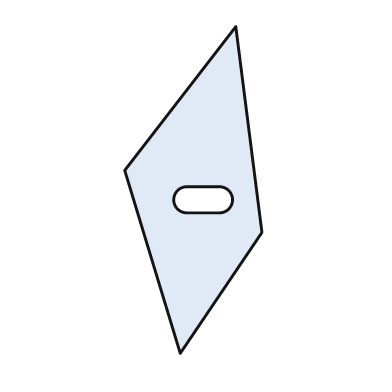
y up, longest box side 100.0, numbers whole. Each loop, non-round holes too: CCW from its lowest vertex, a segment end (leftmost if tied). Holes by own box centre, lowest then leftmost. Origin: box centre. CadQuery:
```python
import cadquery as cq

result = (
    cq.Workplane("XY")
    .moveTo(-4.0, -50.0)
    .lineTo(21.0, -13.0)
    .lineTo(13.0, 50.0)
    .lineTo(-21.0, 6.0)
    .close()
    .moveTo(-2.0, -7.0)
    .lineTo(8.0, -7.0)
    .threePointArc((12.0, -3.0), (8.0, 1.0))
    .lineTo(-2.0, 1.0)
    .threePointArc((-6.0, -3.0), (-2.0, -7.0))
    .close()
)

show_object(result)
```